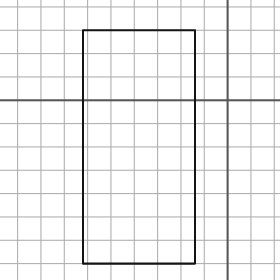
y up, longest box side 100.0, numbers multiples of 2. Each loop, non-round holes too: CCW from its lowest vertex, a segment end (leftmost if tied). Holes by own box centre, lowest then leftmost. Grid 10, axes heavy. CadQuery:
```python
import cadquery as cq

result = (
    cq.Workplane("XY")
    .moveTo(-62.0, -70.0)
    .lineTo(-14.0, -70.0)
    .lineTo(-14.0, 30.0)
    .lineTo(-62.0, 30.0)
    .close()
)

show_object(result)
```